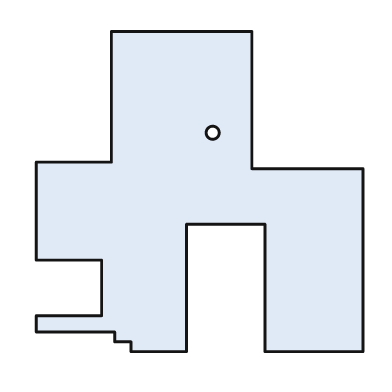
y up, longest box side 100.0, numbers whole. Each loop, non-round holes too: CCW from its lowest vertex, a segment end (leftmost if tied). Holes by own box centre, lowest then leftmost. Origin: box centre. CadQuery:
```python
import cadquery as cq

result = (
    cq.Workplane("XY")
    .moveTo(-21.0, -49.0)
    .lineTo(-4.0, -49.0)
    .lineTo(-4.0, -10.0)
    .lineTo(20.0, -10.0)
    .lineTo(20.0, -49.0)
    .lineTo(50.0, -49.0)
    .lineTo(50.0, 7.0)
    .lineTo(16.0, 7.0)
    .lineTo(16.0, 49.0)
    .lineTo(-27.0, 49.0)
    .lineTo(-27.0, 9.0)
    .lineTo(-50.0, 9.0)
    .lineTo(-50.0, -21.0)
    .lineTo(-30.0, -21.0)
    .lineTo(-30.0, -38.0)
    .lineTo(-50.0, -38.0)
    .lineTo(-50.0, -43.0)
    .lineTo(-26.0, -43.0)
    .lineTo(-26.0, -46.0)
    .lineTo(-21.0, -46.0)
    .close()
    .moveTo(4.0, 18.0)
    .circle(2.0)
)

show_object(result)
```